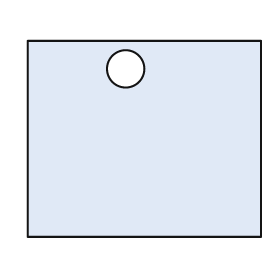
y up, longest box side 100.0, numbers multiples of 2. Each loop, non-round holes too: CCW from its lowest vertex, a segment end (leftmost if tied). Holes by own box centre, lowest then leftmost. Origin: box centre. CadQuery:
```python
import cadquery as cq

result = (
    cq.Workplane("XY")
    .moveTo(-50.0, -42.0)
    .lineTo(50.0, -42.0)
    .lineTo(50.0, 42.0)
    .lineTo(-50.0, 42.0)
    .close()
    .moveTo(-8.0, 30.0)
    .circle(8.0)
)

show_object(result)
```